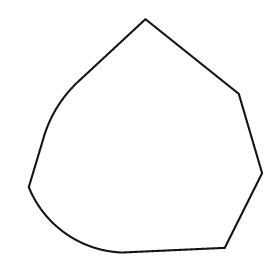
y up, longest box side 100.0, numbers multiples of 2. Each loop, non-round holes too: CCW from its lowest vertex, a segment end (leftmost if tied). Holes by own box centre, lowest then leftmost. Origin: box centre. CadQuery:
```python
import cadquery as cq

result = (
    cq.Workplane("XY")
    .moveTo(-10.0, -50.0)
    .lineTo(34.0, -48.0)
    .lineTo(50.0, -16.0)
    .lineTo(40.0, 18.0)
    .lineTo(0.0, 50.0)
    .lineTo(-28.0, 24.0)
    .threePointArc((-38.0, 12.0), (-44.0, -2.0))
    .lineTo(-50.0, -22.0)
    .threePointArc((-34.0, -42.0), (-10.0, -50.0))
    .close()
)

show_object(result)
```